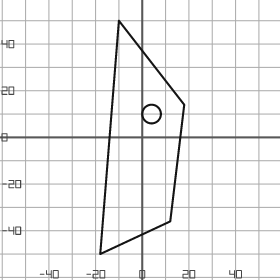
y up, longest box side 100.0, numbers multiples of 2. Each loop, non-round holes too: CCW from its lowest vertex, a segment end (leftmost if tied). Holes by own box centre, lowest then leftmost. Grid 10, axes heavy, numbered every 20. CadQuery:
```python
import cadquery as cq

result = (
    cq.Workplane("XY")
    .moveTo(-18.0, -50.0)
    .lineTo(12.0, -36.0)
    .lineTo(18.0, 14.0)
    .lineTo(-10.0, 50.0)
    .close()
    .moveTo(4.0, 10.0)
    .circle(4.0)
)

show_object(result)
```